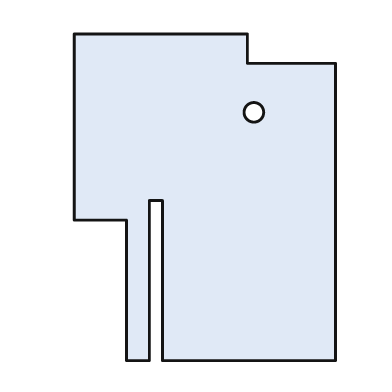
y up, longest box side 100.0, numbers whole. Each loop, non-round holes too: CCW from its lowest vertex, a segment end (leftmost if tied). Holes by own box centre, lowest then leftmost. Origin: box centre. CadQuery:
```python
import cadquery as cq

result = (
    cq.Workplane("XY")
    .moveTo(-24.0, -50.0)
    .lineTo(-17.0, -50.0)
    .lineTo(-17.0, -1.0)
    .lineTo(-13.0, -1.0)
    .lineTo(-13.0, -50.0)
    .lineTo(40.0, -50.0)
    .lineTo(40.0, 41.0)
    .lineTo(13.0, 41.0)
    .lineTo(13.0, 50.0)
    .lineTo(-40.0, 50.0)
    .lineTo(-40.0, -7.0)
    .lineTo(-24.0, -7.0)
    .close()
    .moveTo(15.0, 26.0)
    .circle(3.0)
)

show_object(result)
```